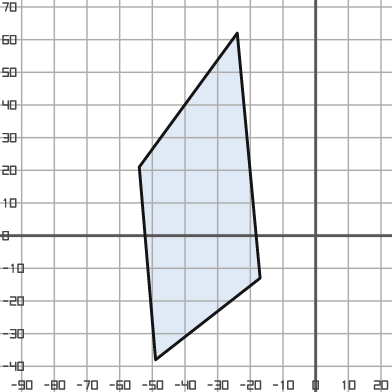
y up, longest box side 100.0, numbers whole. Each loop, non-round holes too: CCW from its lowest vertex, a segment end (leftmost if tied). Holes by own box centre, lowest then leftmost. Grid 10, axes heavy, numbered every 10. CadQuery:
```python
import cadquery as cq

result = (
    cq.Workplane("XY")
    .moveTo(-49.0, -38.0)
    .lineTo(-17.0, -13.0)
    .lineTo(-24.0, 62.0)
    .lineTo(-54.0, 21.0)
    .close()
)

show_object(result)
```